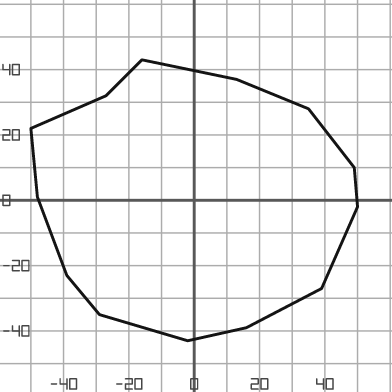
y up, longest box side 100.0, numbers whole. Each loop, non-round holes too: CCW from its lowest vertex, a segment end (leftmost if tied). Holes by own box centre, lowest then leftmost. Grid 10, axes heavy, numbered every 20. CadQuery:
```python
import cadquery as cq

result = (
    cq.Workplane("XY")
    .moveTo(-2.0, -43.0)
    .lineTo(16.0, -39.0)
    .lineTo(39.0, -27.0)
    .lineTo(50.0, -2.0)
    .lineTo(49.0, 10.0)
    .lineTo(35.0, 28.0)
    .lineTo(13.0, 37.0)
    .lineTo(-16.0, 43.0)
    .lineTo(-27.0, 32.0)
    .lineTo(-50.0, 22.0)
    .lineTo(-48.0, 1.0)
    .lineTo(-39.0, -23.0)
    .lineTo(-29.0, -35.0)
    .close()
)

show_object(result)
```